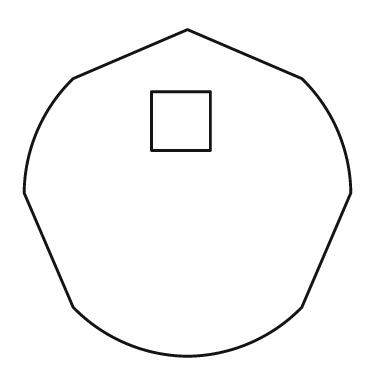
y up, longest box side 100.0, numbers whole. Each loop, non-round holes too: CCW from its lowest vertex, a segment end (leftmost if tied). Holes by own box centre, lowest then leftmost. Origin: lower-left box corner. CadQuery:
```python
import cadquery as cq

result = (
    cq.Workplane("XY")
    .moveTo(50.0, 0.0)
    .threePointArc((69.0, 4.0), (85.0, 15.0))
    .lineTo(100.0, 50.0)
    .threePointArc((96.0, 69.0), (85.0, 85.0))
    .lineTo(50.0, 100.0)
    .lineTo(15.0, 85.0)
    .threePointArc((4.0, 69.0), (0.0, 50.0))
    .lineTo(15.0, 15.0)
    .threePointArc((31.0, 4.0), (50.0, 0.0))
    .close()
    .moveTo(39.0, 63.0)
    .lineTo(57.0, 63.0)
    .lineTo(57.0, 81.0)
    .lineTo(39.0, 81.0)
    .close()
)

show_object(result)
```